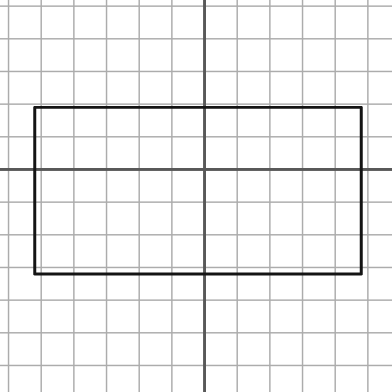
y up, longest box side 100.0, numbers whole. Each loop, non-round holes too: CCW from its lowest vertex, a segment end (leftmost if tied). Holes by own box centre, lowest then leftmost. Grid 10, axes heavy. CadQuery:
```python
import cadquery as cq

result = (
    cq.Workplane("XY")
    .moveTo(-52.0, -32.0)
    .lineTo(48.0, -32.0)
    .lineTo(48.0, 19.0)
    .lineTo(-52.0, 19.0)
    .close()
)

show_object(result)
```